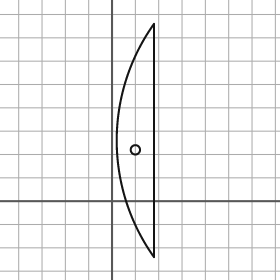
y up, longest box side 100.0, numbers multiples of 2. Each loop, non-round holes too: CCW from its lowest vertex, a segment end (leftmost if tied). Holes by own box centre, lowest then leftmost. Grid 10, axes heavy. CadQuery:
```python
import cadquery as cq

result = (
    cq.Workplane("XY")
    .moveTo(18.0, -24.0)
    .lineTo(18.0, 76.0)
    .threePointArc((2.0, 26.0), (18.0, -24.0))
    .close()
    .moveTo(10.0, 22.0)
    .circle(2.0)
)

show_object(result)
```